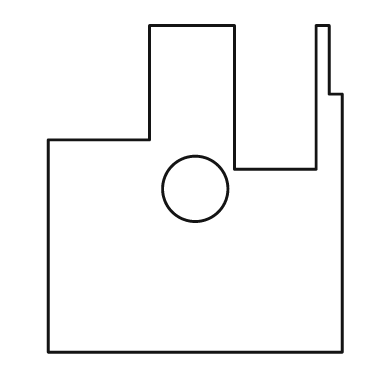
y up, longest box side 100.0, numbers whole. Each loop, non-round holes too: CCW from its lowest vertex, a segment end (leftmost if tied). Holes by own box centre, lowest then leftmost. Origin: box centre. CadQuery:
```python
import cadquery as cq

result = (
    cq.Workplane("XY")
    .moveTo(-45.0, -50.0)
    .lineTo(45.0, -50.0)
    .lineTo(45.0, 29.0)
    .lineTo(41.0, 29.0)
    .lineTo(41.0, 50.0)
    .lineTo(37.0, 50.0)
    .lineTo(37.0, 6.0)
    .lineTo(12.0, 6.0)
    .lineTo(12.0, 50.0)
    .lineTo(-14.0, 50.0)
    .lineTo(-14.0, 15.0)
    .lineTo(-45.0, 15.0)
    .close()
    .moveTo(0.0, 0.0)
    .circle(10.0)
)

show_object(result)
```